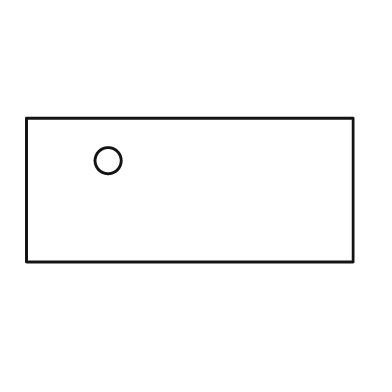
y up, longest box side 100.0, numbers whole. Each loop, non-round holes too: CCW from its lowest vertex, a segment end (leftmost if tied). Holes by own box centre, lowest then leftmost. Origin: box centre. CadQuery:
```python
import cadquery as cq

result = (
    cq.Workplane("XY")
    .moveTo(-50.0, -22.0)
    .lineTo(50.0, -22.0)
    .lineTo(50.0, 22.0)
    .lineTo(-50.0, 22.0)
    .close()
    .moveTo(-25.0, 9.0)
    .circle(4.0)
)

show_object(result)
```